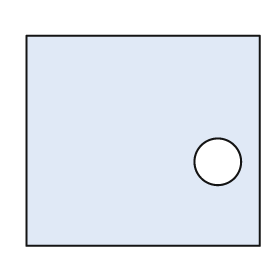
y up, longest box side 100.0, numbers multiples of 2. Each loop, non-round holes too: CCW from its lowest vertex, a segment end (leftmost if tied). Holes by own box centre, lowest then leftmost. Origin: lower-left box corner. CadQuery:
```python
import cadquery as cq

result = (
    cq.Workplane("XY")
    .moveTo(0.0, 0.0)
    .lineTo(100.0, 0.0)
    .lineTo(100.0, 90.0)
    .lineTo(0.0, 90.0)
    .close()
    .moveTo(82.0, 36.0)
    .circle(10.0)
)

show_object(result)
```